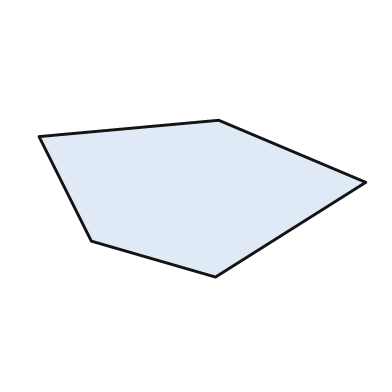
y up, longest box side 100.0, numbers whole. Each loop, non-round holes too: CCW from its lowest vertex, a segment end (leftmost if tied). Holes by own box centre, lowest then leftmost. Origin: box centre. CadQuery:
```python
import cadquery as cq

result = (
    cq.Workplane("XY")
    .moveTo(4.0, -24.0)
    .lineTo(50.0, 5.0)
    .lineTo(5.0, 24.0)
    .lineTo(-50.0, 19.0)
    .lineTo(-34.0, -13.0)
    .close()
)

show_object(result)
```